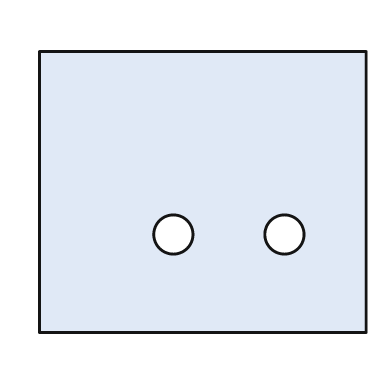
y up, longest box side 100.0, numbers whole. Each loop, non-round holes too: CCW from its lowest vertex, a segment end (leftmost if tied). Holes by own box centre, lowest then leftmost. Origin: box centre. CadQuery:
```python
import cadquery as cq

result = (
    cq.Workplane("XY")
    .moveTo(-50.0, -43.0)
    .lineTo(50.0, -43.0)
    .lineTo(50.0, 43.0)
    .lineTo(-50.0, 43.0)
    .close()
    .moveTo(-9.0, -13.0)
    .circle(6.0)
    .moveTo(25.0, -13.0)
    .circle(6.0)
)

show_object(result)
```